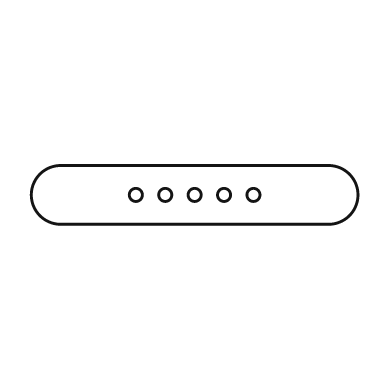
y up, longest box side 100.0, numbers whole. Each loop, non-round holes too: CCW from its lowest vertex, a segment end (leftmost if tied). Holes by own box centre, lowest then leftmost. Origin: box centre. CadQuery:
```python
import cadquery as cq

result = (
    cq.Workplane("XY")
    .moveTo(-41.0, -9.0)
    .lineTo(41.0, -9.0)
    .threePointArc((50.0, 0.0), (41.0, 9.0))
    .lineTo(-41.0, 9.0)
    .threePointArc((-50.0, 0.0), (-41.0, -9.0))
    .close()
    .moveTo(-18.0, 0.0)
    .circle(2.0)
    .moveTo(-9.0, 0.0)
    .circle(2.0)
    .moveTo(0.0, 0.0)
    .circle(2.0)
    .moveTo(9.0, 0.0)
    .circle(2.0)
    .moveTo(18.0, 0.0)
    .circle(2.0)
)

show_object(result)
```